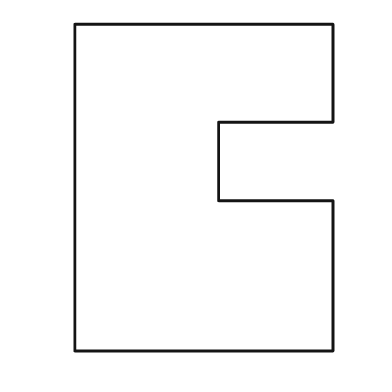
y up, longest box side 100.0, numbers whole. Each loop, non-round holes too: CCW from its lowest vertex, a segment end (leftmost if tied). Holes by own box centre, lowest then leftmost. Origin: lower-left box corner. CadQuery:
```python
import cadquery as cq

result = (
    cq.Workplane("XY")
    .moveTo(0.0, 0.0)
    .lineTo(79.0, 0.0)
    .lineTo(79.0, 46.0)
    .lineTo(44.0, 46.0)
    .lineTo(44.0, 70.0)
    .lineTo(79.0, 70.0)
    .lineTo(79.0, 100.0)
    .lineTo(0.0, 100.0)
    .close()
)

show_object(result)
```